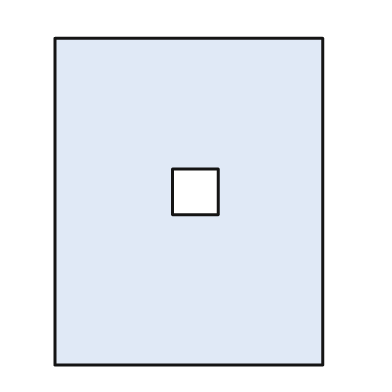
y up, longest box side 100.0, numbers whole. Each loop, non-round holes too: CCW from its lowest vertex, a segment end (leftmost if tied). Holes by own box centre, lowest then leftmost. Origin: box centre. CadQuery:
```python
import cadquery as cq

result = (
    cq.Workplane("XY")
    .moveTo(-41.0, -50.0)
    .lineTo(41.0, -50.0)
    .lineTo(41.0, 50.0)
    .lineTo(-41.0, 50.0)
    .close()
    .moveTo(-5.0, -4.0)
    .lineTo(9.0, -4.0)
    .lineTo(9.0, 10.0)
    .lineTo(-5.0, 10.0)
    .close()
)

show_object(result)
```